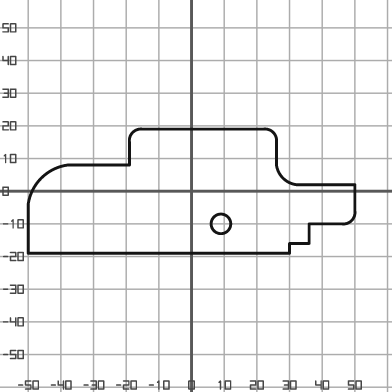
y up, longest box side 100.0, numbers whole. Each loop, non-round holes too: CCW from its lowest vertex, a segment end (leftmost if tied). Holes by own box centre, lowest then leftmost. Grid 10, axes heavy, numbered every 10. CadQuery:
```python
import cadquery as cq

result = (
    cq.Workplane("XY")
    .moveTo(-50.0, -19.0)
    .lineTo(30.0, -19.0)
    .lineTo(30.0, -16.0)
    .lineTo(36.0, -16.0)
    .lineTo(36.0, -10.0)
    .lineTo(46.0, -10.0)
    .threePointArc((49.0, -9.0), (50.0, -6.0))
    .lineTo(50.0, 2.0)
    .lineTo(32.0, 2.0)
    .threePointArc((28.0, 4.0), (26.0, 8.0))
    .lineTo(26.0, 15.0)
    .threePointArc((25.0, 18.0), (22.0, 19.0))
    .lineTo(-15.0, 19.0)
    .threePointArc((-18.0, 18.0), (-19.0, 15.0))
    .lineTo(-19.0, 8.0)
    .lineTo(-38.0, 8.0)
    .threePointArc((-46.0, 4.0), (-50.0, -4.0))
    .close()
    .moveTo(9.0, -10.0)
    .circle(3.0)
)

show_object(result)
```